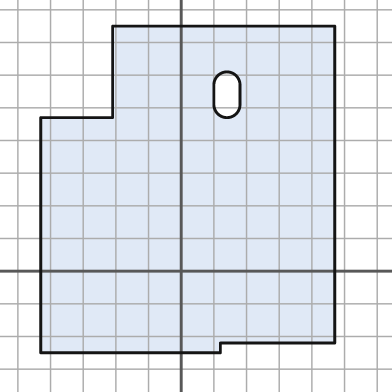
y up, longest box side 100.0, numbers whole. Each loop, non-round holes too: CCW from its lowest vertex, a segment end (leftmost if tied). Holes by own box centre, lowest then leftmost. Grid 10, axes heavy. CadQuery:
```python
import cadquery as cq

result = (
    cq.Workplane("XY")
    .moveTo(-43.0, -25.0)
    .lineTo(12.0, -25.0)
    .lineTo(12.0, -22.0)
    .lineTo(47.0, -22.0)
    .lineTo(47.0, 75.0)
    .lineTo(-21.0, 75.0)
    .lineTo(-21.0, 47.0)
    .lineTo(-43.0, 47.0)
    .close()
    .moveTo(10.0, 51.0)
    .threePointArc((14.0, 47.0), (18.0, 51.0))
    .lineTo(18.0, 57.0)
    .threePointArc((14.0, 61.0), (10.0, 57.0))
    .close()
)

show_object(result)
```